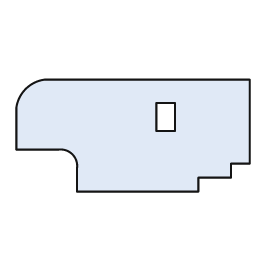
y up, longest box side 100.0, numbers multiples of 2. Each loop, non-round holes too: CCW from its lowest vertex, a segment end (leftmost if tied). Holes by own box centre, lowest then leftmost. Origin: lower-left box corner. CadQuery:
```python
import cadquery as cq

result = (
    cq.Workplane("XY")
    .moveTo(26.0, 0.0)
    .lineTo(78.0, 0.0)
    .lineTo(78.0, 6.0)
    .lineTo(92.0, 6.0)
    .lineTo(92.0, 12.0)
    .lineTo(100.0, 12.0)
    .lineTo(100.0, 48.0)
    .lineTo(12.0, 48.0)
    .threePointArc((4.0, 44.0), (0.0, 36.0))
    .lineTo(0.0, 18.0)
    .lineTo(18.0, 18.0)
    .threePointArc((24.0, 16.0), (26.0, 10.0))
    .close()
    .moveTo(60.0, 26.0)
    .lineTo(68.0, 26.0)
    .lineTo(68.0, 38.0)
    .lineTo(60.0, 38.0)
    .close()
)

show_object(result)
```